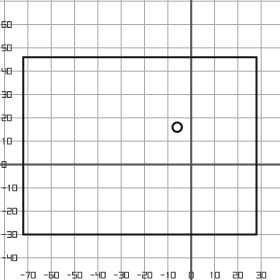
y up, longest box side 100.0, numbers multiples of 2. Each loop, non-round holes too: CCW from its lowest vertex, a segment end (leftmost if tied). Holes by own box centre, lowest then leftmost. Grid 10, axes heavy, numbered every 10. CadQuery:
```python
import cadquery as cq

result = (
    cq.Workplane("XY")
    .moveTo(-72.0, -30.0)
    .lineTo(28.0, -30.0)
    .lineTo(28.0, 46.0)
    .lineTo(-72.0, 46.0)
    .close()
    .moveTo(-6.0, 16.0)
    .circle(2.0)
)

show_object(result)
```